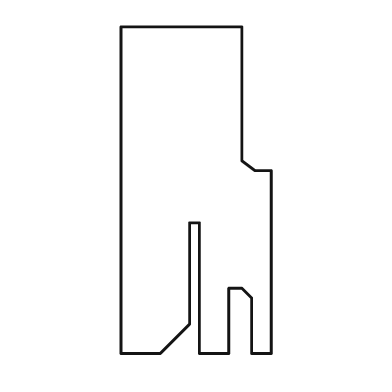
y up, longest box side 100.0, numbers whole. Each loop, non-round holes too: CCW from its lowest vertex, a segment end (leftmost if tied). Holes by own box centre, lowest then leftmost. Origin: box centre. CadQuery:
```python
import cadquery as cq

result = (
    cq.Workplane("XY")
    .moveTo(-23.0, -50.0)
    .lineTo(-11.0, -50.0)
    .lineTo(-2.0, -41.0)
    .lineTo(-2.0, -10.0)
    .lineTo(1.0, -10.0)
    .lineTo(1.0, -50.0)
    .lineTo(10.0, -50.0)
    .lineTo(10.0, -30.0)
    .lineTo(14.0, -30.0)
    .lineTo(17.0, -33.0)
    .lineTo(17.0, -50.0)
    .lineTo(23.0, -50.0)
    .lineTo(23.0, 6.0)
    .lineTo(18.0, 6.0)
    .lineTo(14.0, 9.0)
    .lineTo(14.0, 50.0)
    .lineTo(-23.0, 50.0)
    .close()
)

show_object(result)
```